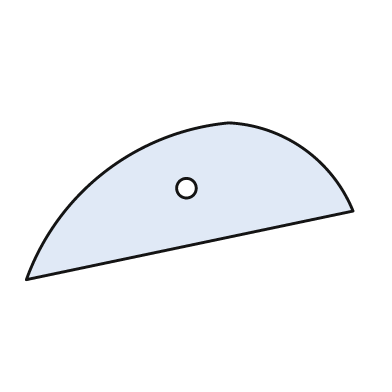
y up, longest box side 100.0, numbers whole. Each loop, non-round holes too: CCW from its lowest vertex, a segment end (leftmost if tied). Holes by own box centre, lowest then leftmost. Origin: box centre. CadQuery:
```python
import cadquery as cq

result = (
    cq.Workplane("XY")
    .moveTo(-50.0, -24.0)
    .lineTo(50.0, -3.0)
    .threePointArc((35.0, 16.0), (12.0, 24.0))
    .threePointArc((-26.0, 9.0), (-50.0, -24.0))
    .close()
    .moveTo(-1.0, 4.0)
    .circle(3.0)
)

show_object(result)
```